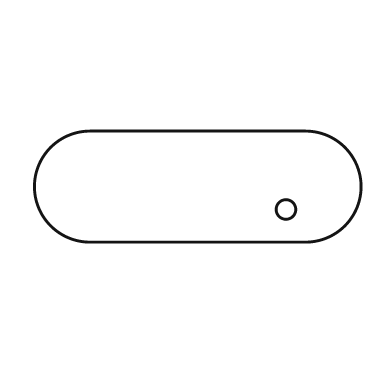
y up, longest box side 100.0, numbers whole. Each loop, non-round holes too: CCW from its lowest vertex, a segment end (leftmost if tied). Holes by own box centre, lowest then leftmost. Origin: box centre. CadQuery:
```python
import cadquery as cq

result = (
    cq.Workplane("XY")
    .moveTo(-33.0, -17.0)
    .lineTo(33.0, -17.0)
    .threePointArc((50.0, 0.0), (33.0, 17.0))
    .lineTo(-33.0, 17.0)
    .threePointArc((-50.0, 0.0), (-33.0, -17.0))
    .close()
    .moveTo(27.0, -7.0)
    .circle(3.0)
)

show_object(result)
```